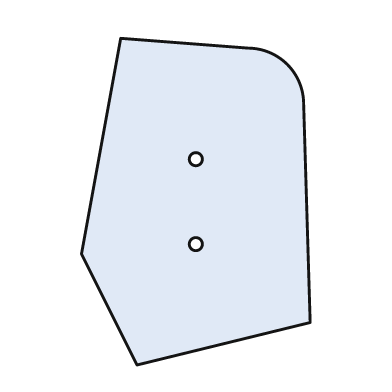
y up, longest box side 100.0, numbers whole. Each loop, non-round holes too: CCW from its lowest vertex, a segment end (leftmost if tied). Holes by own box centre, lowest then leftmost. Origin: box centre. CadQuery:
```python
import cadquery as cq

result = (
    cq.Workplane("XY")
    .moveTo(-18.0, -50.0)
    .lineTo(35.0, -37.0)
    .lineTo(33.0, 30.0)
    .threePointArc((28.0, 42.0), (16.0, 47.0))
    .lineTo(-23.0, 50.0)
    .lineTo(-35.0, -16.0)
    .close()
    .moveTo(0.0, -13.0)
    .circle(2.0)
    .moveTo(0.0, 13.0)
    .circle(2.0)
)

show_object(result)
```